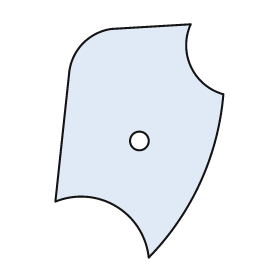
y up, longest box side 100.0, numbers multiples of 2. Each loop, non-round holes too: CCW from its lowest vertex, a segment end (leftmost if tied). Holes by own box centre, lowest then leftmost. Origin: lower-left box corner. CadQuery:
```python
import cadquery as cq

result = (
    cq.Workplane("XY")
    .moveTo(40.0, 0.0)
    .threePointArc((62.0, 32.0), (72.0, 70.0))
    .threePointArc((58.0, 82.0), (58.0, 100.0))
    .lineTo(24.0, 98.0)
    .threePointArc((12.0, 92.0), (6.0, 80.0))
    .lineTo(0.0, 24.0)
    .threePointArc((26.0, 22.0), (40.0, 0.0))
    .close()
    .moveTo(36.0, 50.0)
    .circle(4.0)
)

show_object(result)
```